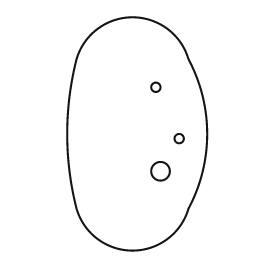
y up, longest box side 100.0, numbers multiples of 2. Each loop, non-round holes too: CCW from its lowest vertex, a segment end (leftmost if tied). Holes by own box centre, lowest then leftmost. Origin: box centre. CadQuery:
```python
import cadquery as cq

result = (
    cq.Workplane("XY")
    .moveTo(-26.0, -32.0)
    .threePointArc((-2.0, -50.0), (22.0, -32.0))
    .threePointArc((30.0, 0.0), (22.0, 32.0))
    .threePointArc((-2.0, 50.0), (-26.0, 32.0))
    .threePointArc((-30.0, 0.0), (-26.0, -32.0))
    .close()
    .moveTo(10.0, -16.0)
    .circle(4.0)
    .moveTo(18.0, -2.0)
    .circle(2.0)
    .moveTo(8.0, 20.0)
    .circle(2.0)
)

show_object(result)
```